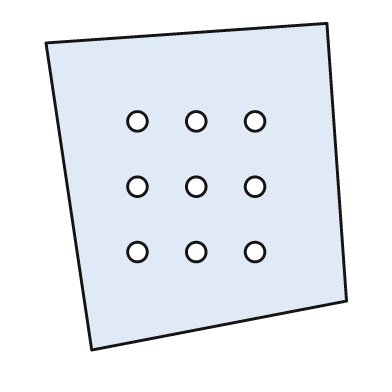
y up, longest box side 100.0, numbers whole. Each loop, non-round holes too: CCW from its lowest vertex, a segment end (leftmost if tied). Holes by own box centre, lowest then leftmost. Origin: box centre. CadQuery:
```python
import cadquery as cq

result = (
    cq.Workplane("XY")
    .moveTo(-32.0, -50.0)
    .lineTo(46.0, -35.0)
    .lineTo(40.0, 50.0)
    .lineTo(-46.0, 44.0)
    .close()
    .moveTo(-18.0, -20.0)
    .circle(3.0)
    .moveTo(0.0, -20.0)
    .circle(3.0)
    .moveTo(18.0, -20.0)
    .circle(3.0)
    .moveTo(-18.0, 0.0)
    .circle(3.0)
    .moveTo(0.0, 0.0)
    .circle(3.0)
    .moveTo(18.0, 0.0)
    .circle(3.0)
    .moveTo(-18.0, 20.0)
    .circle(3.0)
    .moveTo(0.0, 20.0)
    .circle(3.0)
    .moveTo(18.0, 20.0)
    .circle(3.0)
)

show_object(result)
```